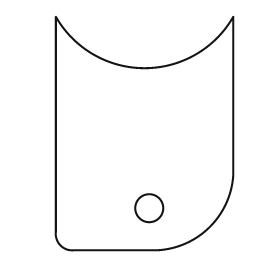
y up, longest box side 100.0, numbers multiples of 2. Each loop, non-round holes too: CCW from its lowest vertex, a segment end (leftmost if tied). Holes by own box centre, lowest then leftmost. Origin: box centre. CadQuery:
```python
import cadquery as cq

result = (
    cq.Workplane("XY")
    .moveTo(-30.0, -50.0)
    .lineTo(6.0, -50.0)
    .threePointArc((28.0, -40.0), (38.0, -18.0))
    .lineTo(38.0, 50.0)
    .threePointArc((0.0, 28.0), (-38.0, 50.0))
    .lineTo(-38.0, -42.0)
    .threePointArc((-36.0, -48.0), (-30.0, -50.0))
    .close()
    .moveTo(2.0, -32.0)
    .circle(6.0)
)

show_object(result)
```